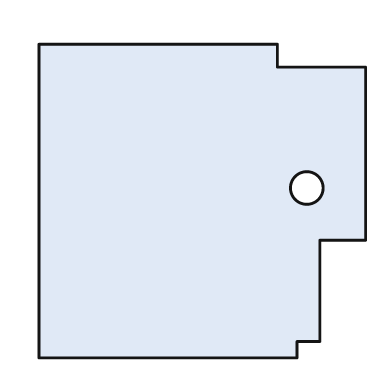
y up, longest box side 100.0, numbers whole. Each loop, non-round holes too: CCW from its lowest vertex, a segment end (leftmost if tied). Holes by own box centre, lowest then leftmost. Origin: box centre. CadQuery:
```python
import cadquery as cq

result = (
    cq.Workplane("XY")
    .moveTo(-50.0, -48.0)
    .lineTo(29.0, -48.0)
    .lineTo(29.0, -43.0)
    .lineTo(36.0, -43.0)
    .lineTo(36.0, -12.0)
    .lineTo(50.0, -12.0)
    .lineTo(50.0, 41.0)
    .lineTo(23.0, 41.0)
    .lineTo(23.0, 48.0)
    .lineTo(-50.0, 48.0)
    .close()
    .moveTo(32.0, 4.0)
    .circle(5.0)
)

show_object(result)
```